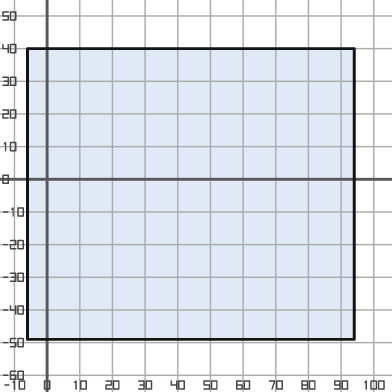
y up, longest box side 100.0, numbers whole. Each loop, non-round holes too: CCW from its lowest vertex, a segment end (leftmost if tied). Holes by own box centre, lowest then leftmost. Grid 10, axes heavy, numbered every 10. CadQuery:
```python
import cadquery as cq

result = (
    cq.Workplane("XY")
    .moveTo(-6.0, -49.0)
    .lineTo(94.0, -49.0)
    .lineTo(94.0, 40.0)
    .lineTo(-6.0, 40.0)
    .close()
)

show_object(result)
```